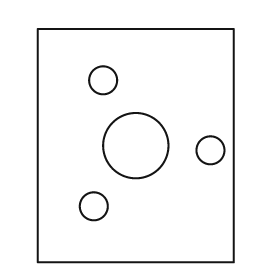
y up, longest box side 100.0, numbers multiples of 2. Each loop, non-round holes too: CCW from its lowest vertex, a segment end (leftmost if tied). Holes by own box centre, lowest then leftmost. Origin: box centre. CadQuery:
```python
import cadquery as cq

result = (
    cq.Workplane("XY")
    .moveTo(-42.0, -50.0)
    .lineTo(42.0, -50.0)
    .lineTo(42.0, 50.0)
    .lineTo(-42.0, 50.0)
    .close()
    .moveTo(-18.0, -26.0)
    .circle(6.0)
    .moveTo(32.0, -2.0)
    .circle(6.0)
    .moveTo(0.0, 0.0)
    .circle(14.0)
    .moveTo(-14.0, 28.0)
    .circle(6.0)
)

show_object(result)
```